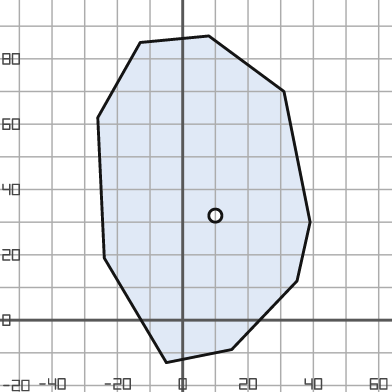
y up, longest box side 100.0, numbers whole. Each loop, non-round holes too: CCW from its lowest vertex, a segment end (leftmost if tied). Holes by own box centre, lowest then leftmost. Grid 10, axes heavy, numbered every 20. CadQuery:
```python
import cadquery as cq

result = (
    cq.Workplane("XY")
    .moveTo(-5.0, -13.0)
    .lineTo(15.0, -9.0)
    .lineTo(35.0, 12.0)
    .lineTo(39.0, 30.0)
    .lineTo(31.0, 70.0)
    .lineTo(8.0, 87.0)
    .lineTo(-13.0, 85.0)
    .lineTo(-26.0, 62.0)
    .lineTo(-24.0, 19.0)
    .close()
    .moveTo(10.0, 32.0)
    .circle(2.0)
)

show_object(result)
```